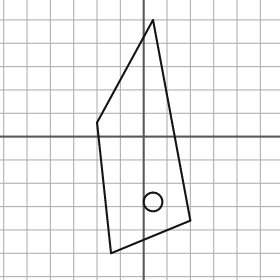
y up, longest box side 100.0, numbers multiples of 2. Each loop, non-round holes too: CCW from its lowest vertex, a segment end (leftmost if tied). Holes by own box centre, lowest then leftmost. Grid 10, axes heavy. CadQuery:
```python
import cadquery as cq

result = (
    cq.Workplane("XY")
    .moveTo(-14.0, -50.0)
    .lineTo(20.0, -36.0)
    .lineTo(4.0, 50.0)
    .lineTo(-20.0, 6.0)
    .close()
    .moveTo(4.0, -28.0)
    .circle(4.0)
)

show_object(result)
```